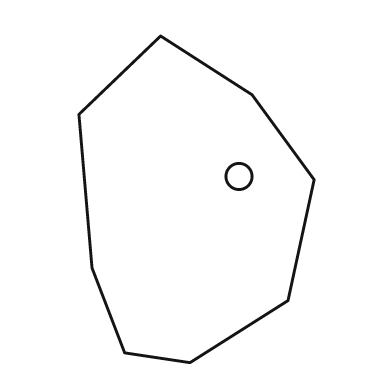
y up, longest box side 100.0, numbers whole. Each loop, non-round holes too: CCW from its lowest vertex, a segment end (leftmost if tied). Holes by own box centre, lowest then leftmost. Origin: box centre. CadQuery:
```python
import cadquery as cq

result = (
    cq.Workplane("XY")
    .moveTo(-2.0, -50.0)
    .lineTo(28.0, -31.0)
    .lineTo(36.0, 6.0)
    .lineTo(17.0, 32.0)
    .lineTo(-11.0, 50.0)
    .lineTo(-36.0, 26.0)
    .lineTo(-32.0, -21.0)
    .lineTo(-22.0, -47.0)
    .close()
    .moveTo(13.0, 7.0)
    .circle(4.0)
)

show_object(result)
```